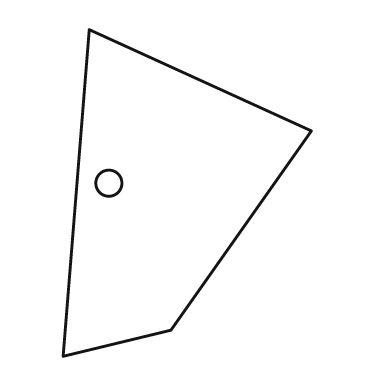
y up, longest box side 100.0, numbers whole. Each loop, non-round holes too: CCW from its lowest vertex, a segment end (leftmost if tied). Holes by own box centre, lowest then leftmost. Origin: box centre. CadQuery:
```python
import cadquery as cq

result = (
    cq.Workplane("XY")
    .moveTo(-38.0, -50.0)
    .lineTo(-5.0, -42.0)
    .lineTo(38.0, 19.0)
    .lineTo(-30.0, 50.0)
    .close()
    .moveTo(-24.0, 3.0)
    .circle(4.0)
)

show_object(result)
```